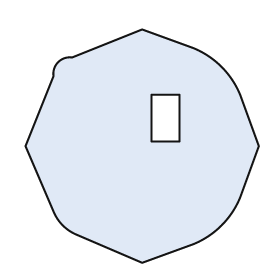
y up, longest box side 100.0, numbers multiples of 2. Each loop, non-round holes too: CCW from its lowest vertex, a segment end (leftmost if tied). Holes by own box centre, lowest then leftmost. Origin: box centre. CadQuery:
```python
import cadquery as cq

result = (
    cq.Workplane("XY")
    .moveTo(0.0, -50.0)
    .lineTo(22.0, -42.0)
    .threePointArc((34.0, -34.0), (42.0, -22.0))
    .lineTo(50.0, 0.0)
    .lineTo(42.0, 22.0)
    .threePointArc((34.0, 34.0), (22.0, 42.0))
    .lineTo(0.0, 50.0)
    .lineTo(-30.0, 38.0)
    .threePointArc((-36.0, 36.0), (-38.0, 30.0))
    .lineTo(-50.0, 0.0)
    .lineTo(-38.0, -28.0)
    .threePointArc((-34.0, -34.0), (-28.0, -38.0))
    .close()
    .moveTo(4.0, 2.0)
    .lineTo(16.0, 2.0)
    .lineTo(16.0, 22.0)
    .lineTo(4.0, 22.0)
    .close()
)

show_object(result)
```